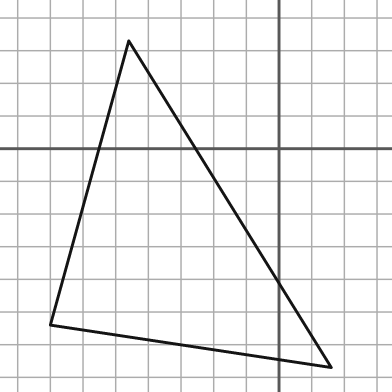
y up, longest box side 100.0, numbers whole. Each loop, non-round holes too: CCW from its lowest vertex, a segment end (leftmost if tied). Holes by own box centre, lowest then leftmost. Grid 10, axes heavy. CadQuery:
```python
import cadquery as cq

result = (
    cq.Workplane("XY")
    .moveTo(16.0, -67.0)
    .lineTo(-46.0, 33.0)
    .lineTo(-70.0, -54.0)
    .close()
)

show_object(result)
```